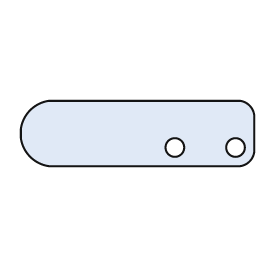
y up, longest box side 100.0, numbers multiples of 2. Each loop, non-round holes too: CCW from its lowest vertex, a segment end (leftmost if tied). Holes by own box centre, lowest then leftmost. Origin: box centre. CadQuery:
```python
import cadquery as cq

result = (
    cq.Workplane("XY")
    .moveTo(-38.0, -14.0)
    .lineTo(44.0, -14.0)
    .threePointArc((48.0, -12.0), (50.0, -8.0))
    .lineTo(50.0, 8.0)
    .threePointArc((48.0, 12.0), (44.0, 14.0))
    .lineTo(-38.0, 14.0)
    .threePointArc((-46.0, 10.0), (-50.0, 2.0))
    .lineTo(-50.0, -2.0)
    .threePointArc((-46.0, -10.0), (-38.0, -14.0))
    .close()
    .moveTo(16.0, -6.0)
    .circle(4.0)
    .moveTo(42.0, -6.0)
    .circle(4.0)
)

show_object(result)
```